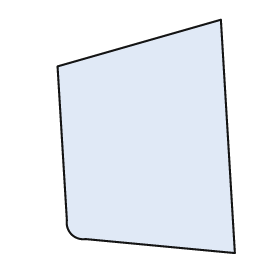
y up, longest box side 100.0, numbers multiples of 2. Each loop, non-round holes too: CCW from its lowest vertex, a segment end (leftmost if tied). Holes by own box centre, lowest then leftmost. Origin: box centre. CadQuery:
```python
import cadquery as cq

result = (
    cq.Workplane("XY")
    .moveTo(38.0, -50.0)
    .lineTo(32.0, 50.0)
    .lineTo(-38.0, 30.0)
    .lineTo(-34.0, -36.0)
    .threePointArc((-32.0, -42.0), (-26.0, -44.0))
    .close()
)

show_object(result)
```